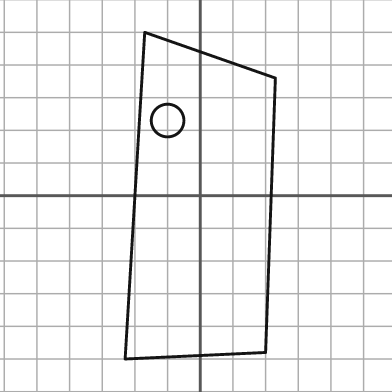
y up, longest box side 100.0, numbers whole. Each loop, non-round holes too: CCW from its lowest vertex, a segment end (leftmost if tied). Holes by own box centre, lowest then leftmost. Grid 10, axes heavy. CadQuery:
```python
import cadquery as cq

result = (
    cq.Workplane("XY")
    .moveTo(-23.0, -50.0)
    .lineTo(20.0, -48.0)
    .lineTo(23.0, 36.0)
    .lineTo(-17.0, 50.0)
    .close()
    .moveTo(-10.0, 23.0)
    .circle(5.0)
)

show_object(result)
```